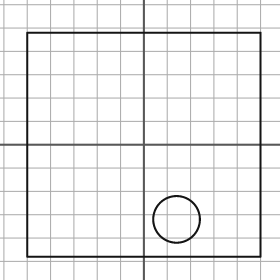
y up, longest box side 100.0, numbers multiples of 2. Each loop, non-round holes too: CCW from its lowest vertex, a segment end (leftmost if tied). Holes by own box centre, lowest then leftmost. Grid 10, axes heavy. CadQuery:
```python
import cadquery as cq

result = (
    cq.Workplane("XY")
    .moveTo(-50.0, -48.0)
    .lineTo(50.0, -48.0)
    .lineTo(50.0, 48.0)
    .lineTo(-50.0, 48.0)
    .close()
    .moveTo(14.0, -32.0)
    .circle(10.0)
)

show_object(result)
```